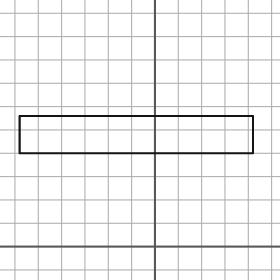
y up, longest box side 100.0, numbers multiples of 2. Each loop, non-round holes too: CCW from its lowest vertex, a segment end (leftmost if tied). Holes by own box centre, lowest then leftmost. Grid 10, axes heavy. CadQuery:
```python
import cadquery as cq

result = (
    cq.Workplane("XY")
    .moveTo(-58.0, 40.0)
    .lineTo(42.0, 40.0)
    .lineTo(42.0, 56.0)
    .lineTo(-58.0, 56.0)
    .close()
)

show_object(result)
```